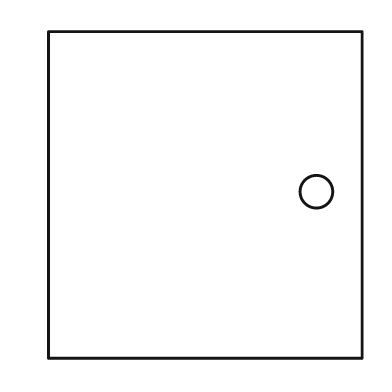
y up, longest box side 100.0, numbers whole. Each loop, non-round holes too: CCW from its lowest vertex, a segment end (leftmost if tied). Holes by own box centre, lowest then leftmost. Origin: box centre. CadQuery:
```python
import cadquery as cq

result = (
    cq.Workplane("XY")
    .moveTo(-48.0, -50.0)
    .lineTo(48.0, -50.0)
    .lineTo(48.0, 50.0)
    .lineTo(-48.0, 50.0)
    .close()
    .moveTo(34.0, 1.0)
    .circle(5.0)
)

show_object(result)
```